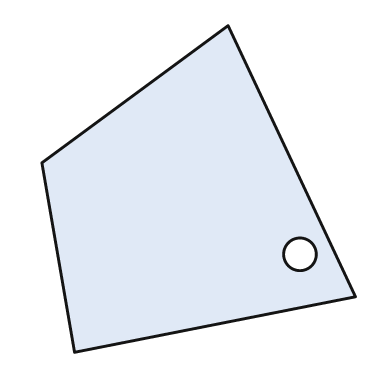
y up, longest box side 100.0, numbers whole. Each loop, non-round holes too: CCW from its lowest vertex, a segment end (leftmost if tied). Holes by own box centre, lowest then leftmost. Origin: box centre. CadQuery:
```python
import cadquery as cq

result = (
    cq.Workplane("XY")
    .moveTo(-38.0, -50.0)
    .lineTo(48.0, -33.0)
    .lineTo(9.0, 50.0)
    .lineTo(-48.0, 8.0)
    .close()
    .moveTo(31.0, -20.0)
    .circle(5.0)
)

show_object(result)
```